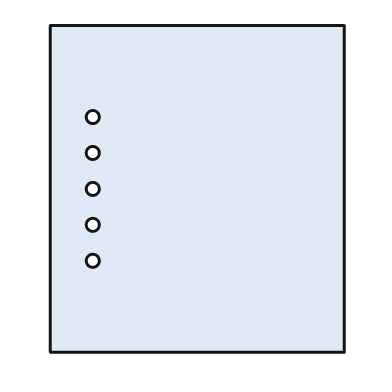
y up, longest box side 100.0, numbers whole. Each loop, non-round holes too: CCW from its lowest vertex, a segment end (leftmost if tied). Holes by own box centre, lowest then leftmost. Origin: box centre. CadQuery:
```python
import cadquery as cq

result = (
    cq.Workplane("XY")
    .moveTo(-45.0, -50.0)
    .lineTo(45.0, -50.0)
    .lineTo(45.0, 50.0)
    .lineTo(-45.0, 50.0)
    .close()
    .moveTo(-32.0, -22.0)
    .circle(2.0)
    .moveTo(-32.0, -11.0)
    .circle(2.0)
    .moveTo(-32.0, 0.0)
    .circle(2.0)
    .moveTo(-32.0, 11.0)
    .circle(2.0)
    .moveTo(-32.0, 22.0)
    .circle(2.0)
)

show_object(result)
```